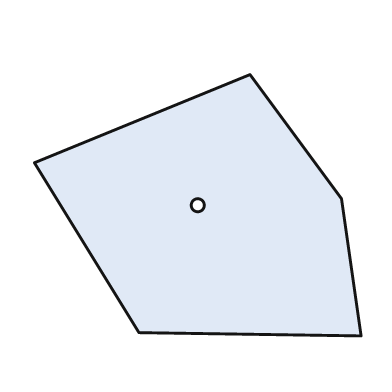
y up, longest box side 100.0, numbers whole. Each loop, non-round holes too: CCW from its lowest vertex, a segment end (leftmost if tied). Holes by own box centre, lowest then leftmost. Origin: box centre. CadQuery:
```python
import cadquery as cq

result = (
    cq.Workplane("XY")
    .moveTo(50.0, -40.0)
    .lineTo(44.0, 2.0)
    .lineTo(16.0, 40.0)
    .lineTo(-50.0, 13.0)
    .lineTo(-18.0, -39.0)
    .close()
    .moveTo(0.0, 0.0)
    .circle(2.0)
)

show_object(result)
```